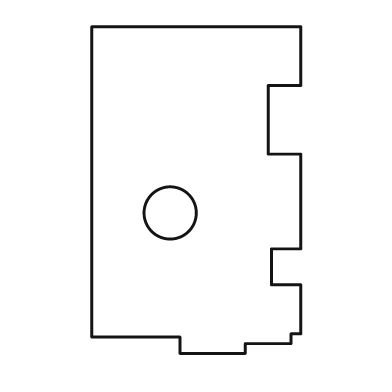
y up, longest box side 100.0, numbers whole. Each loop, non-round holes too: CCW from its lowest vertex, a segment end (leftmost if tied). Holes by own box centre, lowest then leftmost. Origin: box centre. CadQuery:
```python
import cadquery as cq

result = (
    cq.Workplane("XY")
    .moveTo(-5.0, -50.0)
    .lineTo(15.0, -50.0)
    .lineTo(15.0, -47.0)
    .lineTo(29.0, -47.0)
    .lineTo(29.0, -44.0)
    .lineTo(32.0, -44.0)
    .lineTo(32.0, -29.0)
    .lineTo(23.0, -29.0)
    .lineTo(23.0, -18.0)
    .lineTo(32.0, -18.0)
    .lineTo(32.0, 11.0)
    .lineTo(22.0, 11.0)
    .lineTo(22.0, 32.0)
    .lineTo(32.0, 32.0)
    .lineTo(32.0, 50.0)
    .lineTo(-32.0, 50.0)
    .lineTo(-32.0, -45.0)
    .lineTo(-5.0, -45.0)
    .close()
    .moveTo(-8.0, -7.0)
    .circle(8.0)
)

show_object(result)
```